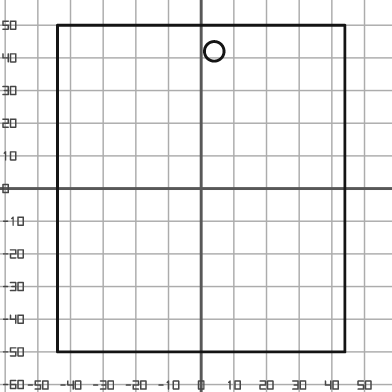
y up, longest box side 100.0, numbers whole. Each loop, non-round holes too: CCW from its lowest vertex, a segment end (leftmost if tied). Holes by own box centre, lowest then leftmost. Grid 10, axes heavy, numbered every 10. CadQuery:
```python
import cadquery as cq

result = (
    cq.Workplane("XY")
    .moveTo(-44.0, -50.0)
    .lineTo(44.0, -50.0)
    .lineTo(44.0, 50.0)
    .lineTo(-44.0, 50.0)
    .close()
    .moveTo(4.0, 42.0)
    .circle(3.0)
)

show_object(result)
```